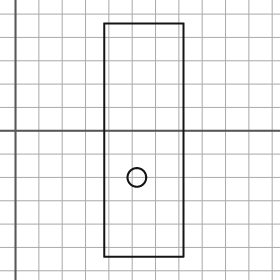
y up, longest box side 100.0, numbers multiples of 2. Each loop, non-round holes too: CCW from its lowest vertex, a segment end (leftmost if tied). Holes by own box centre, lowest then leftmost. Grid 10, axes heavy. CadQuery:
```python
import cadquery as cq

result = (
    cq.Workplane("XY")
    .moveTo(38.0, -54.0)
    .lineTo(72.0, -54.0)
    .lineTo(72.0, 46.0)
    .lineTo(38.0, 46.0)
    .close()
    .moveTo(52.0, -20.0)
    .circle(4.0)
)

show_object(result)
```